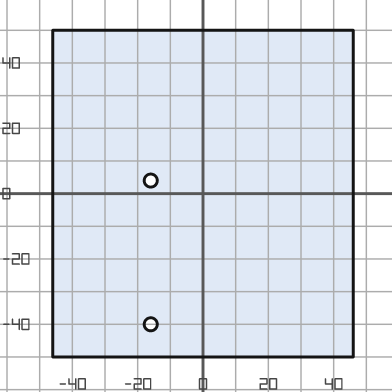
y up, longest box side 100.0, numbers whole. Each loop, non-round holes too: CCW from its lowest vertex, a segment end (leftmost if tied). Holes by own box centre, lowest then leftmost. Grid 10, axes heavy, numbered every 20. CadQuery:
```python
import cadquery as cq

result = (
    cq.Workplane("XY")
    .moveTo(-46.0, -50.0)
    .lineTo(46.0, -50.0)
    .lineTo(46.0, 50.0)
    .lineTo(-46.0, 50.0)
    .close()
    .moveTo(-16.0, -40.0)
    .circle(2.0)
    .moveTo(-16.0, 4.0)
    .circle(2.0)
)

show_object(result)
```